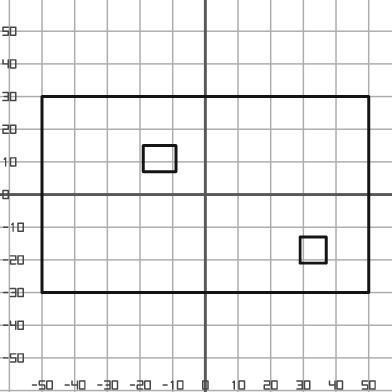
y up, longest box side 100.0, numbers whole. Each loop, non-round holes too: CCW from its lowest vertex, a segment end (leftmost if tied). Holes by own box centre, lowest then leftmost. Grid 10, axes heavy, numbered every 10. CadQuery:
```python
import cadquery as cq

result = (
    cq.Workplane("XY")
    .moveTo(-50.0, -30.0)
    .lineTo(50.0, -30.0)
    .lineTo(50.0, 30.0)
    .lineTo(-50.0, 30.0)
    .close()
    .moveTo(29.0, -21.0)
    .lineTo(37.0, -21.0)
    .lineTo(37.0, -13.0)
    .lineTo(29.0, -13.0)
    .close()
    .moveTo(-19.0, 7.0)
    .lineTo(-9.0, 7.0)
    .lineTo(-9.0, 15.0)
    .lineTo(-19.0, 15.0)
    .close()
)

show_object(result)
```